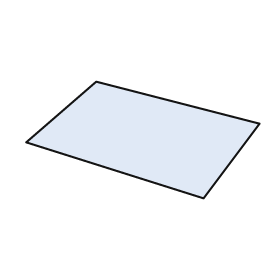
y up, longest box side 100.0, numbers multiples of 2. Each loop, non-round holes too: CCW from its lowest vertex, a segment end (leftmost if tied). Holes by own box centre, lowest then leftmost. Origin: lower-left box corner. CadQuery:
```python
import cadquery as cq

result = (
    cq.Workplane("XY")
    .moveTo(76.0, 0.0)
    .lineTo(100.0, 32.0)
    .lineTo(30.0, 50.0)
    .lineTo(0.0, 24.0)
    .close()
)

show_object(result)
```